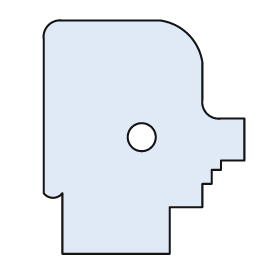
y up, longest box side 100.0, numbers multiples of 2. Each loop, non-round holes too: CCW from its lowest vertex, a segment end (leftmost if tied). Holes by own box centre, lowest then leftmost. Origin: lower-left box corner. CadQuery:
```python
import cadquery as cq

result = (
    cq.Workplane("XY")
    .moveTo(8.0, 0.0)
    .lineTo(54.0, 0.0)
    .lineTo(54.0, 20.0)
    .lineTo(68.0, 20.0)
    .lineTo(68.0, 30.0)
    .lineTo(72.0, 30.0)
    .lineTo(72.0, 36.0)
    .lineTo(76.0, 36.0)
    .lineTo(76.0, 40.0)
    .lineTo(86.0, 40.0)
    .lineTo(86.0, 58.0)
    .lineTo(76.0, 58.0)
    .threePointArc((70.0, 60.0), (68.0, 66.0))
    .lineTo(68.0, 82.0)
    .threePointArc((62.0, 94.0), (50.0, 100.0))
    .lineTo(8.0, 100.0)
    .threePointArc((2.0, 98.0), (0.0, 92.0))
    .lineTo(0.0, 26.0)
    .threePointArc((4.0, 24.0), (8.0, 26.0))
    .close()
    .moveTo(42.0, 50.0)
    .circle(6.0)
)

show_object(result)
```